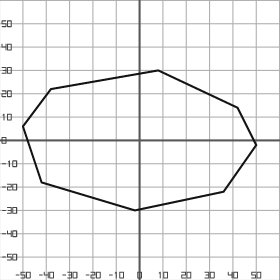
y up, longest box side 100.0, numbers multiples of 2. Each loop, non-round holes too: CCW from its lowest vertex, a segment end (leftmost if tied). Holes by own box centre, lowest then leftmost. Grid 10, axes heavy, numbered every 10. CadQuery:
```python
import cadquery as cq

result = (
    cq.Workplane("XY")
    .moveTo(-2.0, -30.0)
    .lineTo(36.0, -22.0)
    .lineTo(50.0, -2.0)
    .lineTo(42.0, 14.0)
    .lineTo(8.0, 30.0)
    .lineTo(-38.0, 22.0)
    .lineTo(-50.0, 6.0)
    .lineTo(-42.0, -18.0)
    .close()
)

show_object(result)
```